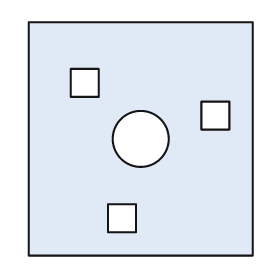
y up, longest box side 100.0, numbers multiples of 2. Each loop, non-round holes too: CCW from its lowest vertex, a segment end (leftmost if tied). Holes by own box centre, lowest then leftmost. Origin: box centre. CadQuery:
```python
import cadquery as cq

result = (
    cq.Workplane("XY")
    .moveTo(-48.0, -50.0)
    .lineTo(48.0, -50.0)
    .lineTo(48.0, 50.0)
    .lineTo(-48.0, 50.0)
    .close()
    .moveTo(-14.0, -40.0)
    .lineTo(-2.0, -40.0)
    .lineTo(-2.0, -28.0)
    .lineTo(-14.0, -28.0)
    .close()
    .moveTo(0.0, 0.0)
    .circle(12.0)
    .moveTo(26.0, 4.0)
    .lineTo(38.0, 4.0)
    .lineTo(38.0, 16.0)
    .lineTo(26.0, 16.0)
    .close()
    .moveTo(-30.0, 18.0)
    .lineTo(-18.0, 18.0)
    .lineTo(-18.0, 30.0)
    .lineTo(-30.0, 30.0)
    .close()
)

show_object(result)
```